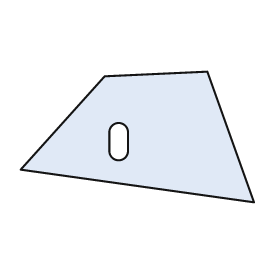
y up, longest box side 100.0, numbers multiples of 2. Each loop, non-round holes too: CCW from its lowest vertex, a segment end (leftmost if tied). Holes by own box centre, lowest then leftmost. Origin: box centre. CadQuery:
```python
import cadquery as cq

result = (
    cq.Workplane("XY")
    .moveTo(50.0, -28.0)
    .lineTo(30.0, 28.0)
    .lineTo(-14.0, 26.0)
    .lineTo(-50.0, -14.0)
    .close()
    .moveTo(-12.0, -6.0)
    .threePointArc((-8.0, -10.0), (-4.0, -6.0))
    .lineTo(-4.0, 2.0)
    .threePointArc((-8.0, 6.0), (-12.0, 2.0))
    .close()
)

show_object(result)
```